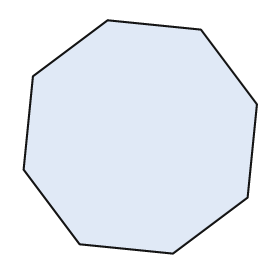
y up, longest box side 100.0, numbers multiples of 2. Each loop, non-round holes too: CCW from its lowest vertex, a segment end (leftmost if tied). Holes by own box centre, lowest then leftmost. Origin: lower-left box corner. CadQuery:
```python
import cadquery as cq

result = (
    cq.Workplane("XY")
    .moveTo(64.0, 0.0)
    .lineTo(96.0, 24.0)
    .lineTo(100.0, 64.0)
    .lineTo(76.0, 96.0)
    .lineTo(36.0, 100.0)
    .lineTo(4.0, 76.0)
    .lineTo(0.0, 36.0)
    .lineTo(24.0, 4.0)
    .close()
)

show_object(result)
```